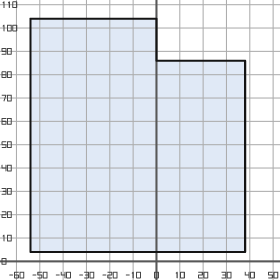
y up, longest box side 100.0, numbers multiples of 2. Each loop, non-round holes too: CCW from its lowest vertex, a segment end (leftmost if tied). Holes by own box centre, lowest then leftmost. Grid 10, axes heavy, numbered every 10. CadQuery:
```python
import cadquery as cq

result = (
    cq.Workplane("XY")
    .moveTo(-54.0, 4.0)
    .lineTo(38.0, 4.0)
    .lineTo(38.0, 86.0)
    .lineTo(0.0, 86.0)
    .lineTo(0.0, 104.0)
    .lineTo(-54.0, 104.0)
    .close()
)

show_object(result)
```